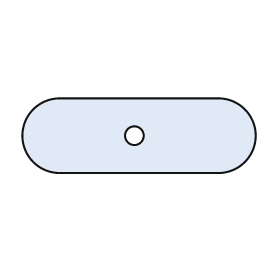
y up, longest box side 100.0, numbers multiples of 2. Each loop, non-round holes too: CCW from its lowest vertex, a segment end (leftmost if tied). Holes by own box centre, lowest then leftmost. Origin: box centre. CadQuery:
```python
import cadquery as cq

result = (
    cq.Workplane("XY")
    .moveTo(-34.0, -16.0)
    .lineTo(34.0, -16.0)
    .threePointArc((50.0, 0.0), (34.0, 16.0))
    .lineTo(-34.0, 16.0)
    .threePointArc((-50.0, 0.0), (-34.0, -16.0))
    .close()
    .moveTo(-2.0, 0.0)
    .circle(4.0)
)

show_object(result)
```